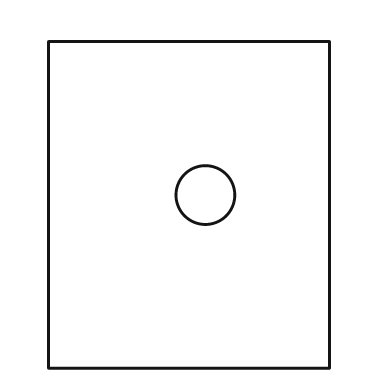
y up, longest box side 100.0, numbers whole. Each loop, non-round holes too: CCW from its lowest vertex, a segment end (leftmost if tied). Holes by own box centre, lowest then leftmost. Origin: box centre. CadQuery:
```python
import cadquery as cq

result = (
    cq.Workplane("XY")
    .moveTo(-43.0, -50.0)
    .lineTo(43.0, -50.0)
    .lineTo(43.0, 50.0)
    .lineTo(-43.0, 50.0)
    .close()
    .moveTo(5.0, 3.0)
    .circle(9.0)
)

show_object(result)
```